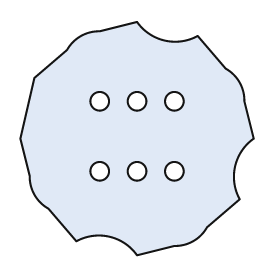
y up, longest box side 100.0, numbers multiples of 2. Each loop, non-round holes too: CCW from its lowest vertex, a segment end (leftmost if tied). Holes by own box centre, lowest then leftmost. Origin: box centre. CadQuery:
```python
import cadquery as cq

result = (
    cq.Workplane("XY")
    .moveTo(0.0, -50.0)
    .lineTo(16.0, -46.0)
    .threePointArc((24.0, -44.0), (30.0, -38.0))
    .lineTo(44.0, -26.0)
    .threePointArc((42.0, -12.0), (50.0, 0.0))
    .lineTo(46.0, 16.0)
    .threePointArc((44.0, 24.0), (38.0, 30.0))
    .lineTo(26.0, 44.0)
    .threePointArc((12.0, 42.0), (0.0, 50.0))
    .lineTo(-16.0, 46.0)
    .threePointArc((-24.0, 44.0), (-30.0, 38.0))
    .lineTo(-44.0, 26.0)
    .lineTo(-50.0, 0.0)
    .lineTo(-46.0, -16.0)
    .threePointArc((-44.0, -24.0), (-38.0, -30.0))
    .lineTo(-26.0, -44.0)
    .threePointArc((-12.0, -42.0), (0.0, -50.0))
    .close()
    .moveTo(-16.0, -14.0)
    .circle(4.0)
    .moveTo(0.0, -14.0)
    .circle(4.0)
    .moveTo(16.0, -14.0)
    .circle(4.0)
    .moveTo(-16.0, 16.0)
    .circle(4.0)
    .moveTo(0.0, 16.0)
    .circle(4.0)
    .moveTo(16.0, 16.0)
    .circle(4.0)
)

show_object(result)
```